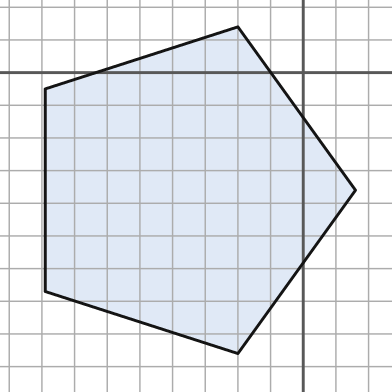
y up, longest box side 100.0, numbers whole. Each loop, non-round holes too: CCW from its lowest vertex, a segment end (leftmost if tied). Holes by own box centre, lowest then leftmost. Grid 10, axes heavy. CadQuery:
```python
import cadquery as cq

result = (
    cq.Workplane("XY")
    .moveTo(-20.0, -86.0)
    .lineTo(16.0, -36.0)
    .lineTo(-20.0, 14.0)
    .lineTo(-79.0, -5.0)
    .lineTo(-79.0, -67.0)
    .close()
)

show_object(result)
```